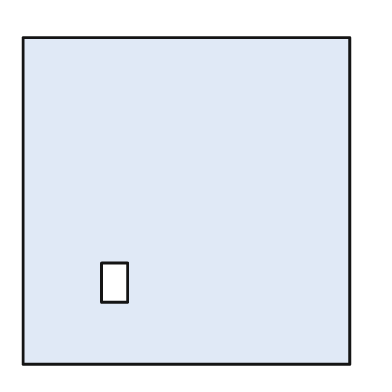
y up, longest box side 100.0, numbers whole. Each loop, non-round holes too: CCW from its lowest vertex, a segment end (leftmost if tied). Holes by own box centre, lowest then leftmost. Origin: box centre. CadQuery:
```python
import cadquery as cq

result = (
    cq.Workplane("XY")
    .moveTo(-50.0, -50.0)
    .lineTo(50.0, -50.0)
    .lineTo(50.0, 50.0)
    .lineTo(-50.0, 50.0)
    .close()
    .moveTo(-26.0, -31.0)
    .lineTo(-18.0, -31.0)
    .lineTo(-18.0, -19.0)
    .lineTo(-26.0, -19.0)
    .close()
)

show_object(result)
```